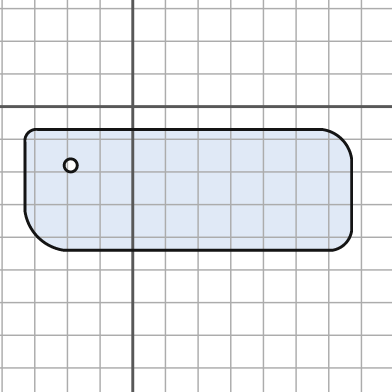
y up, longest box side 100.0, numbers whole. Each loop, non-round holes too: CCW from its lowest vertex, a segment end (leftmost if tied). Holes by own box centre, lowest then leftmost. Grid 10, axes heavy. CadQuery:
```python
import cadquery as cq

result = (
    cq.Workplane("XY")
    .moveTo(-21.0, -44.0)
    .lineTo(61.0, -44.0)
    .threePointArc((65.0, -42.0), (67.0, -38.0))
    .lineTo(67.0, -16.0)
    .threePointArc((64.0, -10.0), (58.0, -7.0))
    .lineTo(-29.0, -7.0)
    .threePointArc((-32.0, -8.0), (-33.0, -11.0))
    .lineTo(-33.0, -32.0)
    .threePointArc((-29.0, -40.0), (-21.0, -44.0))
    .close()
    .moveTo(-19.0, -18.0)
    .circle(2.0)
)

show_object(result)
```